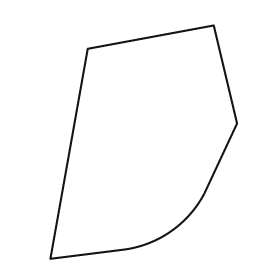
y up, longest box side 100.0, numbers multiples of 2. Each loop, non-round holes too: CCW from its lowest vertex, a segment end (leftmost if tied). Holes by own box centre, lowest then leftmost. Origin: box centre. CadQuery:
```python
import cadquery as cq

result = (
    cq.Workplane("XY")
    .moveTo(-40.0, -50.0)
    .lineTo(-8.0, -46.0)
    .threePointArc((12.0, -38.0), (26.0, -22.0))
    .lineTo(40.0, 8.0)
    .lineTo(30.0, 50.0)
    .lineTo(-24.0, 40.0)
    .close()
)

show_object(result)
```